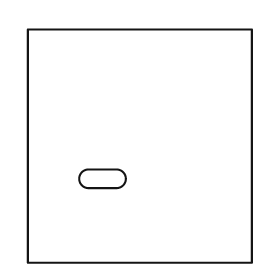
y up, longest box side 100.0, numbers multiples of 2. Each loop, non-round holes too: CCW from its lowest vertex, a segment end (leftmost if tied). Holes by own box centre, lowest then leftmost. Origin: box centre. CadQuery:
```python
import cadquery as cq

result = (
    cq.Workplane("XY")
    .moveTo(-48.0, -50.0)
    .lineTo(48.0, -50.0)
    .lineTo(48.0, 50.0)
    .lineTo(-48.0, 50.0)
    .close()
    .moveTo(-22.0, -18.0)
    .lineTo(-10.0, -18.0)
    .threePointArc((-6.0, -14.0), (-10.0, -10.0))
    .lineTo(-22.0, -10.0)
    .threePointArc((-26.0, -14.0), (-22.0, -18.0))
    .close()
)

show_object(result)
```